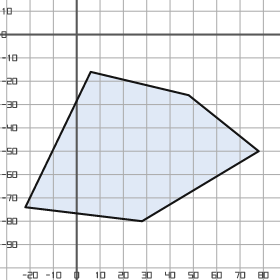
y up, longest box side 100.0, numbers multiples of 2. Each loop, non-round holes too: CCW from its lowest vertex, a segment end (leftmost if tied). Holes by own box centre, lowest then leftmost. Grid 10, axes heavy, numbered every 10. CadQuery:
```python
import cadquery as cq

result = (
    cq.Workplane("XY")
    .moveTo(28.0, -80.0)
    .lineTo(78.0, -50.0)
    .lineTo(48.0, -26.0)
    .lineTo(6.0, -16.0)
    .lineTo(-22.0, -74.0)
    .close()
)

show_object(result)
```